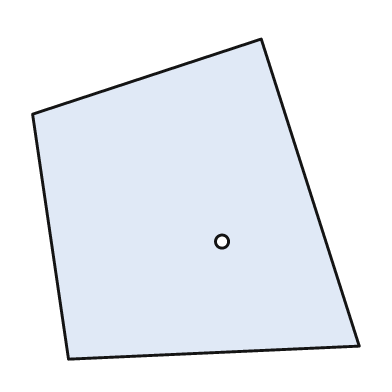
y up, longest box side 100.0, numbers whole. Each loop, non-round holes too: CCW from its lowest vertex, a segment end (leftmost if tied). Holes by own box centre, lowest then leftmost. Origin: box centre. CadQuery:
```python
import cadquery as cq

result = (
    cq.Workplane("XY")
    .moveTo(-39.0, -49.0)
    .lineTo(50.0, -45.0)
    .lineTo(20.0, 49.0)
    .lineTo(-50.0, 26.0)
    .close()
    .moveTo(8.0, -13.0)
    .circle(2.0)
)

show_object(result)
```